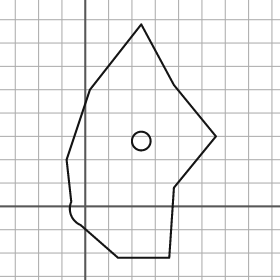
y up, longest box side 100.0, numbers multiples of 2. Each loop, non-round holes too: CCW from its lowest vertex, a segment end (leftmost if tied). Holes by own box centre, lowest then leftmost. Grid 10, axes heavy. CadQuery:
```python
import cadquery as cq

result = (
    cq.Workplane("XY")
    .moveTo(14.0, -22.0)
    .lineTo(36.0, -22.0)
    .lineTo(38.0, 8.0)
    .lineTo(56.0, 30.0)
    .lineTo(38.0, 52.0)
    .lineTo(24.0, 78.0)
    .lineTo(2.0, 50.0)
    .lineTo(-8.0, 20.0)
    .lineTo(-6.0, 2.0)
    .threePointArc((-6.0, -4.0), (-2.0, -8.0))
    .close()
    .moveTo(24.0, 28.0)
    .circle(4.0)
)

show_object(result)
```